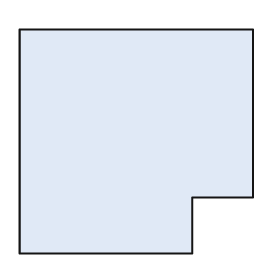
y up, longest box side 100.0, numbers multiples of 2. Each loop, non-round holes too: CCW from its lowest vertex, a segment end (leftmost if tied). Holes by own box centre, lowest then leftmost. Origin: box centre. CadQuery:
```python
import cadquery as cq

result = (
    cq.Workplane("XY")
    .moveTo(-50.0, -48.0)
    .lineTo(24.0, -48.0)
    .lineTo(24.0, -24.0)
    .lineTo(50.0, -24.0)
    .lineTo(50.0, 48.0)
    .lineTo(-50.0, 48.0)
    .close()
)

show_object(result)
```